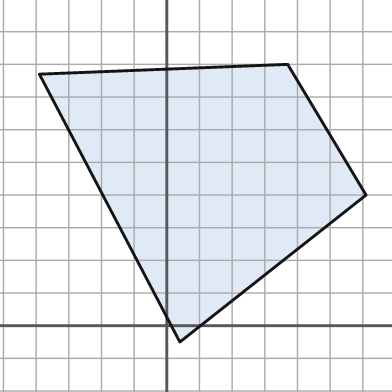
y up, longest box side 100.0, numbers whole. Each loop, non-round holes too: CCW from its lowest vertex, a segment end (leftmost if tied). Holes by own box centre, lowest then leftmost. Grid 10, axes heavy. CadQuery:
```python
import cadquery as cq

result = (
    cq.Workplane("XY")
    .moveTo(4.0, -5.0)
    .lineTo(61.0, 40.0)
    .lineTo(37.0, 80.0)
    .lineTo(-39.0, 77.0)
    .close()
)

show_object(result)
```